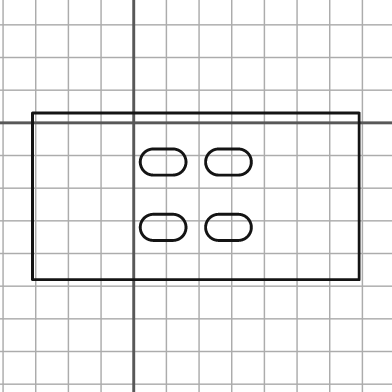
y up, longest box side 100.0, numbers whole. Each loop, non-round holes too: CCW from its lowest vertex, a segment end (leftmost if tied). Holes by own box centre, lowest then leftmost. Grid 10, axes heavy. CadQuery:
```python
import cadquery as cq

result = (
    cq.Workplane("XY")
    .moveTo(-31.0, -48.0)
    .lineTo(69.0, -48.0)
    .lineTo(69.0, 3.0)
    .lineTo(-31.0, 3.0)
    .close()
    .moveTo(6.0, -36.0)
    .lineTo(12.0, -36.0)
    .threePointArc((16.0, -32.0), (12.0, -28.0))
    .lineTo(6.0, -28.0)
    .threePointArc((2.0, -32.0), (6.0, -36.0))
    .close()
    .moveTo(26.0, -36.0)
    .lineTo(32.0, -36.0)
    .threePointArc((36.0, -32.0), (32.0, -28.0))
    .lineTo(26.0, -28.0)
    .threePointArc((22.0, -32.0), (26.0, -36.0))
    .close()
    .moveTo(6.0, -16.0)
    .lineTo(12.0, -16.0)
    .threePointArc((16.0, -12.0), (12.0, -8.0))
    .lineTo(6.0, -8.0)
    .threePointArc((2.0, -12.0), (6.0, -16.0))
    .close()
    .moveTo(26.0, -16.0)
    .lineTo(32.0, -16.0)
    .threePointArc((36.0, -12.0), (32.0, -8.0))
    .lineTo(26.0, -8.0)
    .threePointArc((22.0, -12.0), (26.0, -16.0))
    .close()
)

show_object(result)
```